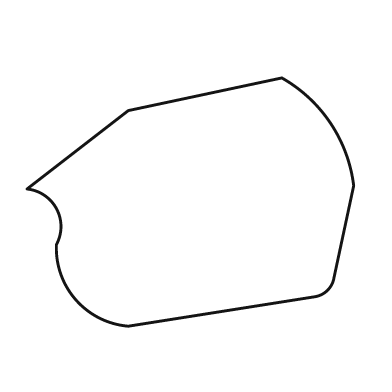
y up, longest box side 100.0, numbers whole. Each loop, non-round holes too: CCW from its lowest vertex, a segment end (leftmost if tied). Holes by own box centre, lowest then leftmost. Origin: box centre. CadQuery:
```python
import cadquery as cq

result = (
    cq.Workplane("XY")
    .moveTo(-19.0, -38.0)
    .lineTo(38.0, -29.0)
    .threePointArc((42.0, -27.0), (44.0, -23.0))
    .lineTo(50.0, 5.0)
    .threePointArc((43.0, 24.0), (28.0, 38.0))
    .lineTo(-19.0, 28.0)
    .lineTo(-50.0, 4.0)
    .threePointArc((-41.0, -2.0), (-41.0, -13.0))
    .threePointArc((-35.0, -30.0), (-19.0, -38.0))
    .close()
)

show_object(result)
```